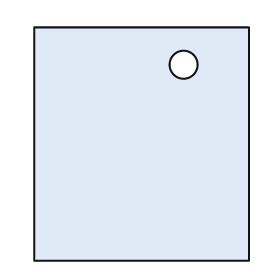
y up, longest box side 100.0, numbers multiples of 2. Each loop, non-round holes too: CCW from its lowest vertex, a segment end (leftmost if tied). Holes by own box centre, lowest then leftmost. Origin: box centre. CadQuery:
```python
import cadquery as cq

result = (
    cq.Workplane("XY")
    .moveTo(-46.0, -50.0)
    .lineTo(46.0, -50.0)
    .lineTo(46.0, 50.0)
    .lineTo(-46.0, 50.0)
    .close()
    .moveTo(18.0, 34.0)
    .circle(6.0)
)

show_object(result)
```